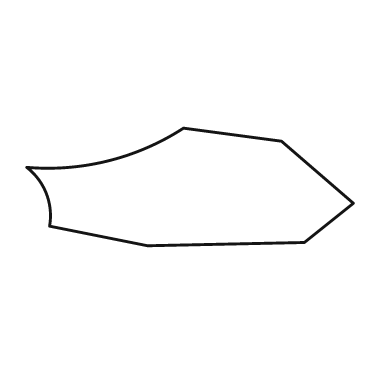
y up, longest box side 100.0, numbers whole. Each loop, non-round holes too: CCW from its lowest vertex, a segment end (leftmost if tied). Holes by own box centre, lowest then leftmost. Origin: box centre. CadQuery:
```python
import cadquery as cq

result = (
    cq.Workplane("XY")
    .moveTo(-13.0, -18.0)
    .lineTo(35.0, -17.0)
    .lineTo(50.0, -5.0)
    .lineTo(28.0, 14.0)
    .lineTo(-2.0, 18.0)
    .threePointArc((-25.0, 8.0), (-50.0, 6.0))
    .threePointArc((-44.0, -2.0), (-43.0, -12.0))
    .close()
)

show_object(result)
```